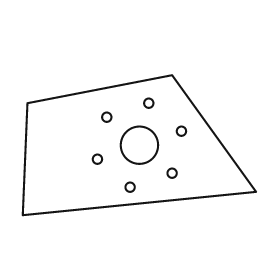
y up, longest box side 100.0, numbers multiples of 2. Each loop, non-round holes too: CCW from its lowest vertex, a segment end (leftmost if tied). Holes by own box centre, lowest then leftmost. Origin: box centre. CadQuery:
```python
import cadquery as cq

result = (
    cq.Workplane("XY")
    .moveTo(-50.0, -30.0)
    .lineTo(50.0, -20.0)
    .lineTo(14.0, 30.0)
    .lineTo(-48.0, 18.0)
    .close()
    .moveTo(-4.0, -18.0)
    .circle(2.0)
    .moveTo(14.0, -12.0)
    .circle(2.0)
    .moveTo(-18.0, -6.0)
    .circle(2.0)
    .moveTo(0.0, 0.0)
    .circle(8.0)
    .moveTo(18.0, 6.0)
    .circle(2.0)
    .moveTo(-14.0, 12.0)
    .circle(2.0)
    .moveTo(4.0, 18.0)
    .circle(2.0)
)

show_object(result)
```